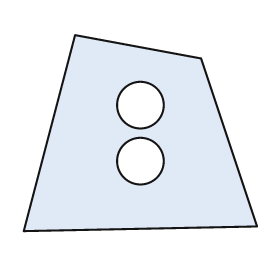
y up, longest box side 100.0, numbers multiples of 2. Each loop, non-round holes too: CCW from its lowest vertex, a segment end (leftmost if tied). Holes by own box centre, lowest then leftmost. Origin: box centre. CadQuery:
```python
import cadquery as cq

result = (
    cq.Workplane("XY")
    .moveTo(-50.0, -42.0)
    .lineTo(50.0, -40.0)
    .lineTo(26.0, 32.0)
    .lineTo(-28.0, 42.0)
    .close()
    .moveTo(0.0, -12.0)
    .circle(10.0)
    .moveTo(0.0, 12.0)
    .circle(10.0)
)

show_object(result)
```